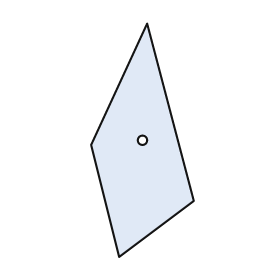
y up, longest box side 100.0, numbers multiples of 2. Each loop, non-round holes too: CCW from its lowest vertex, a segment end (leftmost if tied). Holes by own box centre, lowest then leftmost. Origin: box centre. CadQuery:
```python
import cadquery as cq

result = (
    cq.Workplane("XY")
    .moveTo(-10.0, -50.0)
    .lineTo(22.0, -26.0)
    .lineTo(2.0, 50.0)
    .lineTo(-22.0, -2.0)
    .close()
    .moveTo(0.0, 0.0)
    .circle(2.0)
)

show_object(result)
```